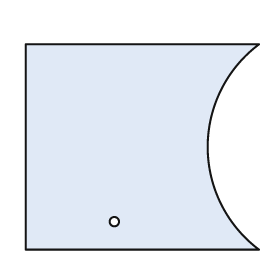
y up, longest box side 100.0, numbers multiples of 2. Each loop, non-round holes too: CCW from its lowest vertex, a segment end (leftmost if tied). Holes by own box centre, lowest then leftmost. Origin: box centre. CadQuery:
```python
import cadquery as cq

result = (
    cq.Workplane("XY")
    .moveTo(-50.0, -44.0)
    .lineTo(50.0, -44.0)
    .threePointArc((28.0, 0.0), (50.0, 44.0))
    .lineTo(-50.0, 44.0)
    .close()
    .moveTo(-12.0, -32.0)
    .circle(2.0)
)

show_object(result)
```